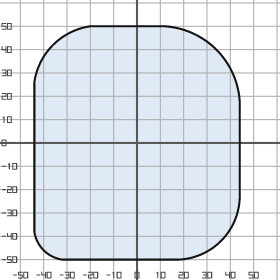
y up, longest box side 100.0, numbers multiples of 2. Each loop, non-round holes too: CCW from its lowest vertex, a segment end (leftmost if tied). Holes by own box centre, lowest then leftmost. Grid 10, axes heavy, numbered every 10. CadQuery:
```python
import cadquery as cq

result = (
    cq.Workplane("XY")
    .moveTo(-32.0, -50.0)
    .lineTo(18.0, -50.0)
    .threePointArc((36.0, -42.0), (44.0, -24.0))
    .lineTo(44.0, 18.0)
    .threePointArc((34.0, 40.0), (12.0, 50.0))
    .lineTo(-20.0, 50.0)
    .threePointArc((-36.0, 42.0), (-44.0, 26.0))
    .lineTo(-44.0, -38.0)
    .threePointArc((-40.0, -46.0), (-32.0, -50.0))
    .close()
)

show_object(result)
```